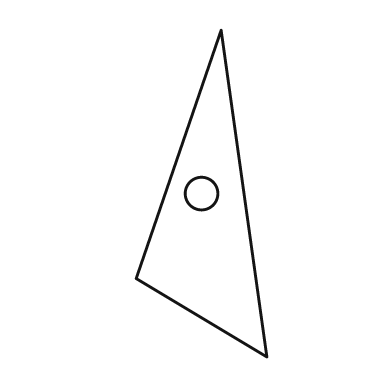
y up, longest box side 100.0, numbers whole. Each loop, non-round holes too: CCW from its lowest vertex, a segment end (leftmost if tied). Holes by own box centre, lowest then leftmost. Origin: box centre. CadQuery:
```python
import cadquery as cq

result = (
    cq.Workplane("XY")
    .moveTo(20.0, -50.0)
    .lineTo(6.0, 50.0)
    .lineTo(-20.0, -26.0)
    .close()
    .moveTo(0.0, 0.0)
    .circle(5.0)
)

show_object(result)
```